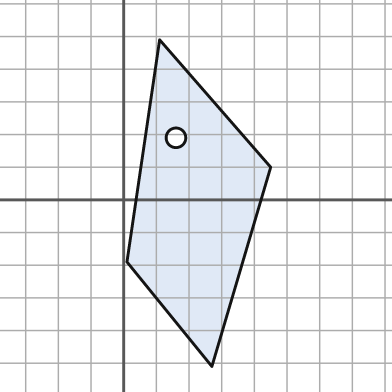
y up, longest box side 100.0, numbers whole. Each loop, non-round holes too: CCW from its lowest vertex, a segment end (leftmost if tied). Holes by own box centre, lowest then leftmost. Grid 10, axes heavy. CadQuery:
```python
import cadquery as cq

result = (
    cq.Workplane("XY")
    .moveTo(27.0, -51.0)
    .lineTo(45.0, 10.0)
    .lineTo(11.0, 49.0)
    .lineTo(1.0, -19.0)
    .close()
    .moveTo(16.0, 19.0)
    .circle(3.0)
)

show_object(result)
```